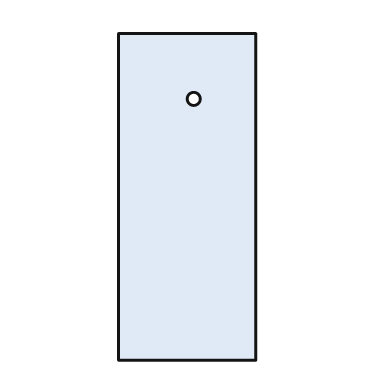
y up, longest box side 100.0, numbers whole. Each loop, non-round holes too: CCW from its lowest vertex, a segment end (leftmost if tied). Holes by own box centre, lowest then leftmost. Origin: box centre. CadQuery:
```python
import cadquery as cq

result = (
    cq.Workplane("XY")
    .moveTo(-21.0, -50.0)
    .lineTo(21.0, -50.0)
    .lineTo(21.0, 50.0)
    .lineTo(-21.0, 50.0)
    .close()
    .moveTo(2.0, 30.0)
    .circle(2.0)
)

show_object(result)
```